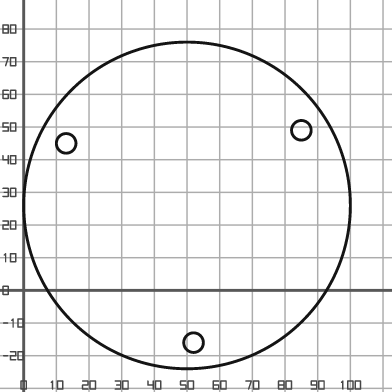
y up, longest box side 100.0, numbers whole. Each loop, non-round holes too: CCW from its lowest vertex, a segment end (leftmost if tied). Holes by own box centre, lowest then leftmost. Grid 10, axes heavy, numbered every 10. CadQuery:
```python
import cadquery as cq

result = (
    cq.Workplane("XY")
    .moveTo(50.0, 26.0)
    .circle(50.0)
    .moveTo(52.0, -16.0)
    .circle(3.0)
    .moveTo(13.0, 45.0)
    .circle(3.0)
    .moveTo(85.0, 49.0)
    .circle(3.0)
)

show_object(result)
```